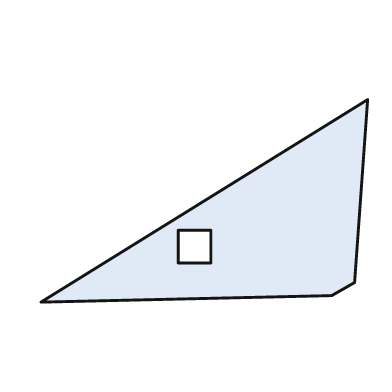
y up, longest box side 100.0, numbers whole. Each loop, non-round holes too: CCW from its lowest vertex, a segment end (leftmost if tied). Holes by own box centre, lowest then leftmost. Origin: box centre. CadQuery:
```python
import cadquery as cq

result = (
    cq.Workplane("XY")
    .moveTo(-50.0, -31.0)
    .lineTo(39.0, -29.0)
    .lineTo(46.0, -25.0)
    .lineTo(50.0, 31.0)
    .close()
    .moveTo(-8.0, -19.0)
    .lineTo(2.0, -19.0)
    .lineTo(2.0, -9.0)
    .lineTo(-8.0, -9.0)
    .close()
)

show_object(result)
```